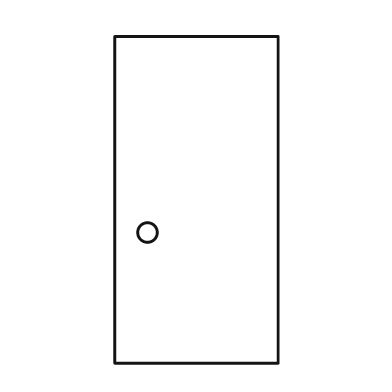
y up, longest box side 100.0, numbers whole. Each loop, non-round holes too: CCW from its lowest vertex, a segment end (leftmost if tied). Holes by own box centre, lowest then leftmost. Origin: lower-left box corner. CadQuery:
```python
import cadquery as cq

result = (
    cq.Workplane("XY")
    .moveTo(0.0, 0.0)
    .lineTo(50.0, 0.0)
    .lineTo(50.0, 100.0)
    .lineTo(0.0, 100.0)
    .close()
    .moveTo(10.0, 40.0)
    .circle(3.0)
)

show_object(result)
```